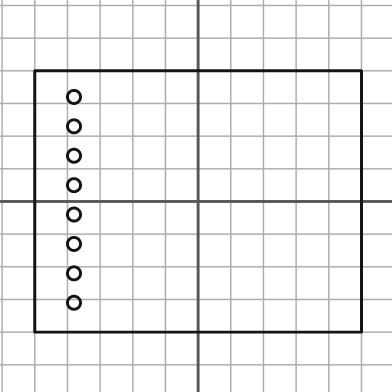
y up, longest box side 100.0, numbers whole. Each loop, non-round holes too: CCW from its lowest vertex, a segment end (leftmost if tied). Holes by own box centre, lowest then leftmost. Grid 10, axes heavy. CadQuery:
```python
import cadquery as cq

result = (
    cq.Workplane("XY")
    .moveTo(-50.0, -40.0)
    .lineTo(50.0, -40.0)
    .lineTo(50.0, 40.0)
    .lineTo(-50.0, 40.0)
    .close()
    .moveTo(-38.0, -31.0)
    .circle(2.0)
    .moveTo(-38.0, -22.0)
    .circle(2.0)
    .moveTo(-38.0, -13.0)
    .circle(2.0)
    .moveTo(-38.0, -4.0)
    .circle(2.0)
    .moveTo(-38.0, 5.0)
    .circle(2.0)
    .moveTo(-38.0, 14.0)
    .circle(2.0)
    .moveTo(-38.0, 23.0)
    .circle(2.0)
    .moveTo(-38.0, 32.0)
    .circle(2.0)
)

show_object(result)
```